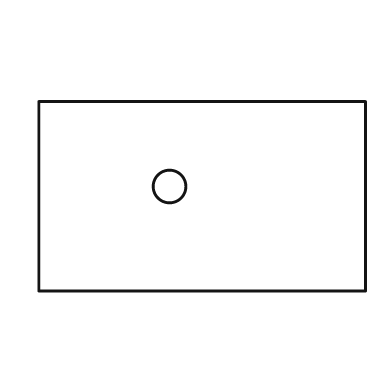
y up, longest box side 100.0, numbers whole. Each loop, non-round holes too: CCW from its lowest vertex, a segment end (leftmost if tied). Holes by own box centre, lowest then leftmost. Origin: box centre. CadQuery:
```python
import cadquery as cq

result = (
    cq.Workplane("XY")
    .moveTo(-50.0, -29.0)
    .lineTo(50.0, -29.0)
    .lineTo(50.0, 29.0)
    .lineTo(-50.0, 29.0)
    .close()
    .moveTo(-10.0, 3.0)
    .circle(5.0)
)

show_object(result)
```